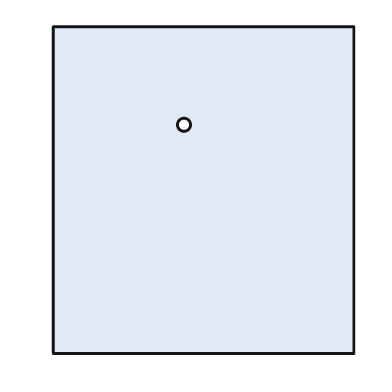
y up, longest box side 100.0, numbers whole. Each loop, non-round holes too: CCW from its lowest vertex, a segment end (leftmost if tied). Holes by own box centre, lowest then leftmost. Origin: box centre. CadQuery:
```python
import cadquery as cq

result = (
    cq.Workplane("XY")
    .moveTo(-46.0, -50.0)
    .lineTo(46.0, -50.0)
    .lineTo(46.0, 50.0)
    .lineTo(-46.0, 50.0)
    .close()
    .moveTo(-6.0, 20.0)
    .circle(2.0)
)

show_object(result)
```